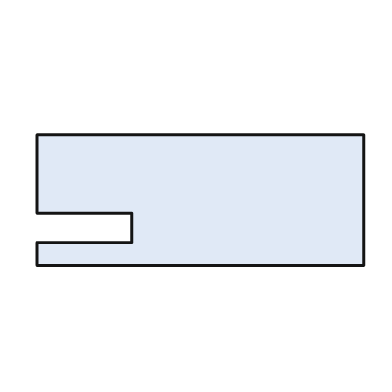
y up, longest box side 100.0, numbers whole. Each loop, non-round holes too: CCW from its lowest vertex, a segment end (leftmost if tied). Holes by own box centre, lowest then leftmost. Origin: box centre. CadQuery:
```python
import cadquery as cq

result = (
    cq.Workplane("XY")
    .moveTo(-50.0, -20.0)
    .lineTo(50.0, -20.0)
    .lineTo(50.0, 20.0)
    .lineTo(-50.0, 20.0)
    .lineTo(-50.0, -4.0)
    .lineTo(-21.0, -4.0)
    .lineTo(-21.0, -13.0)
    .lineTo(-50.0, -13.0)
    .close()
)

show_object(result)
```